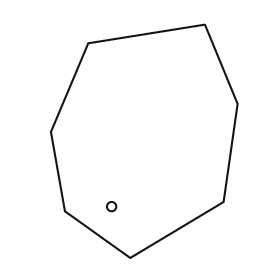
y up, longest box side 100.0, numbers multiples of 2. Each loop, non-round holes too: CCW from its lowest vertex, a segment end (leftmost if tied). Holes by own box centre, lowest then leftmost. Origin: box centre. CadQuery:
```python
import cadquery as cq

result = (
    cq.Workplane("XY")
    .moveTo(-6.0, -50.0)
    .lineTo(34.0, -26.0)
    .lineTo(40.0, 16.0)
    .lineTo(26.0, 50.0)
    .lineTo(-24.0, 42.0)
    .lineTo(-40.0, 4.0)
    .lineTo(-34.0, -30.0)
    .close()
    .moveTo(-14.0, -28.0)
    .circle(2.0)
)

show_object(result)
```